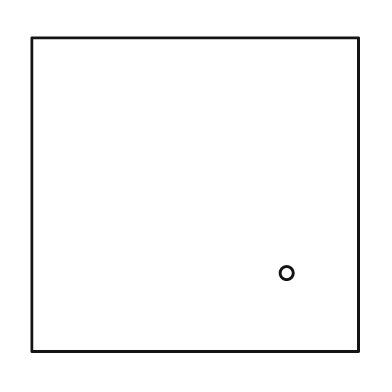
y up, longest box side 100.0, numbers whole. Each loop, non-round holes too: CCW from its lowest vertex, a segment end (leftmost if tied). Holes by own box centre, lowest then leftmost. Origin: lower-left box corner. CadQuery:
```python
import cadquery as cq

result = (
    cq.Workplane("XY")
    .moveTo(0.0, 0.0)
    .lineTo(100.0, 0.0)
    .lineTo(100.0, 96.0)
    .lineTo(0.0, 96.0)
    .close()
    .moveTo(78.0, 24.0)
    .circle(2.0)
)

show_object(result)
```